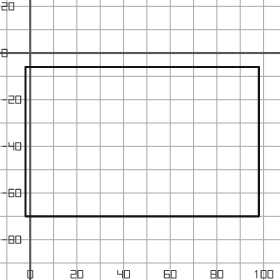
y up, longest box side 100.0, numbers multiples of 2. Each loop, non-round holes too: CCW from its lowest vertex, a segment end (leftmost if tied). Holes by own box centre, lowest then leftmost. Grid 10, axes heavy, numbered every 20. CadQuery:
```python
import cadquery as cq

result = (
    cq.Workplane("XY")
    .moveTo(-2.0, -70.0)
    .lineTo(98.0, -70.0)
    .lineTo(98.0, -6.0)
    .lineTo(-2.0, -6.0)
    .close()
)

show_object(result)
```